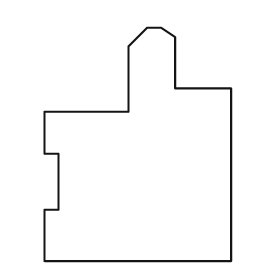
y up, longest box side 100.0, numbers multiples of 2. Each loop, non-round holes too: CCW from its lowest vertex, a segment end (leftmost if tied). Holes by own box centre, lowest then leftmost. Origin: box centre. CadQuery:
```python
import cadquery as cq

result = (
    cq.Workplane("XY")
    .moveTo(-40.0, -50.0)
    .lineTo(40.0, -50.0)
    .lineTo(40.0, 24.0)
    .lineTo(16.0, 24.0)
    .lineTo(16.0, 46.0)
    .lineTo(10.0, 50.0)
    .lineTo(4.0, 50.0)
    .lineTo(-4.0, 42.0)
    .lineTo(-4.0, 14.0)
    .lineTo(-40.0, 14.0)
    .lineTo(-40.0, -4.0)
    .lineTo(-34.0, -4.0)
    .lineTo(-34.0, -28.0)
    .lineTo(-40.0, -28.0)
    .close()
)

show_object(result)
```